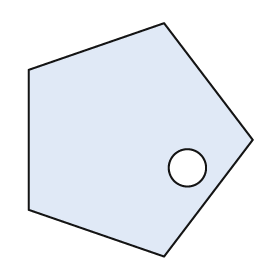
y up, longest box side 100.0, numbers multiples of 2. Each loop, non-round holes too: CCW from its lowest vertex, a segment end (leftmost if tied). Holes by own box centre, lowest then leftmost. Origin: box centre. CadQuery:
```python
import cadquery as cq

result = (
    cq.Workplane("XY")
    .moveTo(10.0, -50.0)
    .lineTo(48.0, 0.0)
    .lineTo(10.0, 50.0)
    .lineTo(-48.0, 30.0)
    .lineTo(-48.0, -30.0)
    .close()
    .moveTo(20.0, -12.0)
    .circle(8.0)
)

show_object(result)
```